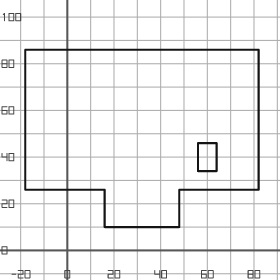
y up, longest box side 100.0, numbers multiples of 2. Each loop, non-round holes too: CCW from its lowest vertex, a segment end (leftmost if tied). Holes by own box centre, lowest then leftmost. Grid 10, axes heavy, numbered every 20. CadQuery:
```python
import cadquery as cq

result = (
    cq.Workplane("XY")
    .moveTo(16.0, 10.0)
    .lineTo(48.0, 10.0)
    .lineTo(48.0, 26.0)
    .lineTo(82.0, 26.0)
    .lineTo(82.0, 86.0)
    .lineTo(-18.0, 86.0)
    .lineTo(-18.0, 26.0)
    .lineTo(16.0, 26.0)
    .close()
    .moveTo(56.0, 34.0)
    .lineTo(64.0, 34.0)
    .lineTo(64.0, 46.0)
    .lineTo(56.0, 46.0)
    .close()
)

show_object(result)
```